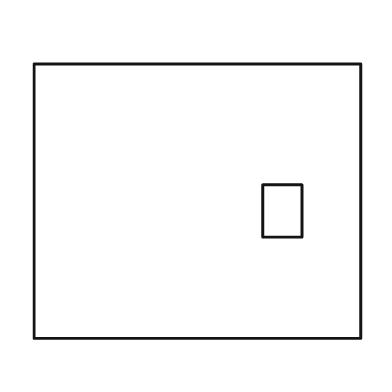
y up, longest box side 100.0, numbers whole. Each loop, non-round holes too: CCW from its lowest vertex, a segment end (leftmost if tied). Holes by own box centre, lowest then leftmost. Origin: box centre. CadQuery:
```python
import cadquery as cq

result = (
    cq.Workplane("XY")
    .moveTo(-50.0, -42.0)
    .lineTo(50.0, -42.0)
    .lineTo(50.0, 42.0)
    .lineTo(-50.0, 42.0)
    .close()
    .moveTo(20.0, -11.0)
    .lineTo(32.0, -11.0)
    .lineTo(32.0, 5.0)
    .lineTo(20.0, 5.0)
    .close()
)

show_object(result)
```